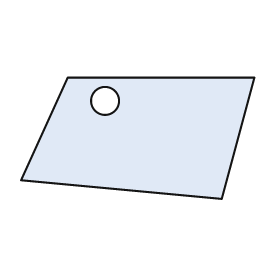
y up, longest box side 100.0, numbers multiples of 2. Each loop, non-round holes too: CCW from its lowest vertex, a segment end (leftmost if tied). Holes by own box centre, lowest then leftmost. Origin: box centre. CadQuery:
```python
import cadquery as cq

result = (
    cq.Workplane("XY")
    .moveTo(36.0, -26.0)
    .lineTo(50.0, 26.0)
    .lineTo(-30.0, 26.0)
    .lineTo(-50.0, -18.0)
    .close()
    .moveTo(-14.0, 16.0)
    .circle(6.0)
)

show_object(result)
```